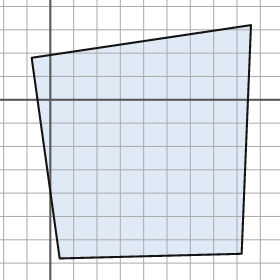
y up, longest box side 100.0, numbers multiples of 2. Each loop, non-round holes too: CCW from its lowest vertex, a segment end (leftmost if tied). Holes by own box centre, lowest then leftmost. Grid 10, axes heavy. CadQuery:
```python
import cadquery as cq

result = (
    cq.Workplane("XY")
    .moveTo(4.0, -68.0)
    .lineTo(82.0, -66.0)
    .lineTo(86.0, 32.0)
    .lineTo(-8.0, 18.0)
    .close()
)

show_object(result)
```